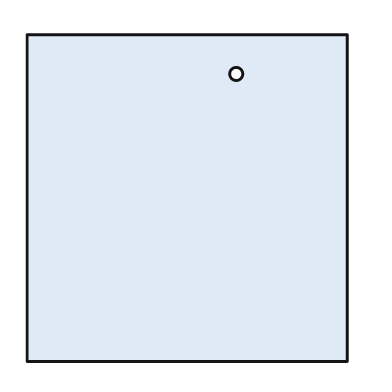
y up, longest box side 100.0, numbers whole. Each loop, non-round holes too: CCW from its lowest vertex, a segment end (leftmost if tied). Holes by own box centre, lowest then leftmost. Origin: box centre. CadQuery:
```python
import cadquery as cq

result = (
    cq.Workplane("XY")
    .moveTo(-49.0, -50.0)
    .lineTo(49.0, -50.0)
    .lineTo(49.0, 50.0)
    .lineTo(-49.0, 50.0)
    .close()
    .moveTo(15.0, 38.0)
    .circle(2.0)
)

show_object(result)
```